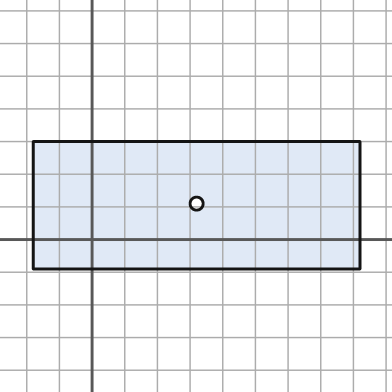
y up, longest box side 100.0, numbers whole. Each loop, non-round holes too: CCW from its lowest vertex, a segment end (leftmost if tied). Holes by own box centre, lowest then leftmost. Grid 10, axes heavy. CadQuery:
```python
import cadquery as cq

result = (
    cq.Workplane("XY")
    .moveTo(-18.0, -9.0)
    .lineTo(82.0, -9.0)
    .lineTo(82.0, 30.0)
    .lineTo(-18.0, 30.0)
    .close()
    .moveTo(32.0, 11.0)
    .circle(2.0)
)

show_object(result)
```